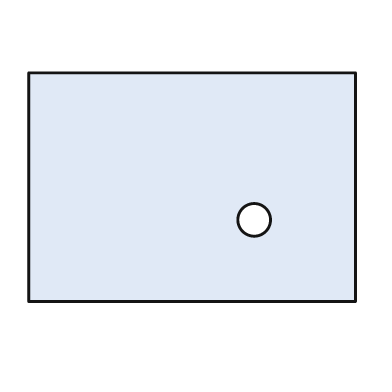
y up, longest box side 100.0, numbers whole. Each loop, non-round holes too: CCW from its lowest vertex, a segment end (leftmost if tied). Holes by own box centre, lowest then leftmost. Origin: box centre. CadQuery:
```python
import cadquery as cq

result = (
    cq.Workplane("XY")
    .moveTo(-50.0, -35.0)
    .lineTo(50.0, -35.0)
    .lineTo(50.0, 35.0)
    .lineTo(-50.0, 35.0)
    .close()
    .moveTo(19.0, -10.0)
    .circle(5.0)
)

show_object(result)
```